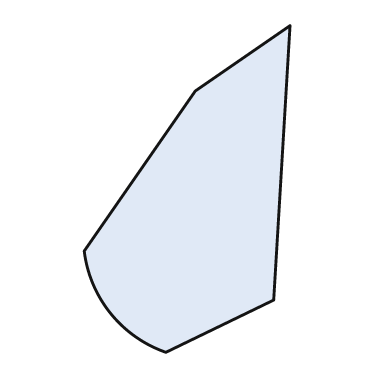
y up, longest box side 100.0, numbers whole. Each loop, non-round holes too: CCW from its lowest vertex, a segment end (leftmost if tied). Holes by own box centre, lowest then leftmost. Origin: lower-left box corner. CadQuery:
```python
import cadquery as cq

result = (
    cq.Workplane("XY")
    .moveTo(25.0, 0.0)
    .lineTo(58.0, 16.0)
    .lineTo(63.0, 100.0)
    .lineTo(34.0, 80.0)
    .lineTo(0.0, 31.0)
    .threePointArc((8.0, 12.0), (25.0, 0.0))
    .close()
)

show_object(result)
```